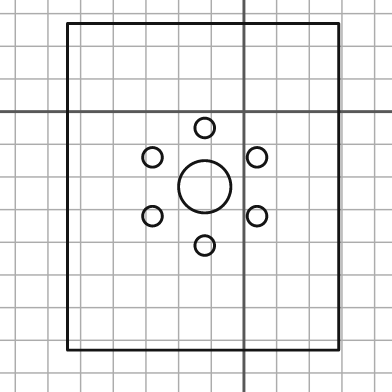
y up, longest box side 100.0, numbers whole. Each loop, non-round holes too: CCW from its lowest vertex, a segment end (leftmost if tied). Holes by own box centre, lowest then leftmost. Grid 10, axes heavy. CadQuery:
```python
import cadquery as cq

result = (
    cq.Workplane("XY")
    .moveTo(-54.0, -73.0)
    .lineTo(29.0, -73.0)
    .lineTo(29.0, 27.0)
    .lineTo(-54.0, 27.0)
    .close()
    .moveTo(-12.0, -41.0)
    .circle(3.0)
    .moveTo(-28.0, -32.0)
    .circle(3.0)
    .moveTo(4.0, -32.0)
    .circle(3.0)
    .moveTo(-12.0, -23.0)
    .circle(8.0)
    .moveTo(-28.0, -14.0)
    .circle(3.0)
    .moveTo(4.0, -14.0)
    .circle(3.0)
    .moveTo(-12.0, -5.0)
    .circle(3.0)
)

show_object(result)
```